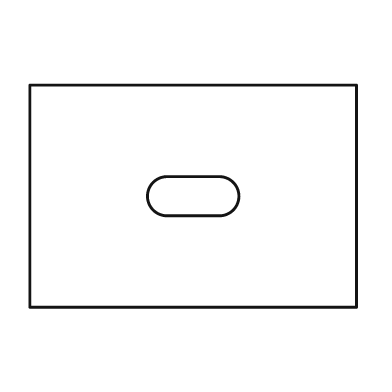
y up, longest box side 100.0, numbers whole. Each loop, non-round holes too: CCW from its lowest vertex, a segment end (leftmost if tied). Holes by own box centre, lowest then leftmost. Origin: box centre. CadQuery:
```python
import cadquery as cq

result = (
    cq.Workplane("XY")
    .moveTo(-50.0, -34.0)
    .lineTo(50.0, -34.0)
    .lineTo(50.0, 34.0)
    .lineTo(-50.0, 34.0)
    .close()
    .moveTo(-8.0, -6.0)
    .lineTo(8.0, -6.0)
    .threePointArc((14.0, 0.0), (8.0, 6.0))
    .lineTo(-8.0, 6.0)
    .threePointArc((-14.0, 0.0), (-8.0, -6.0))
    .close()
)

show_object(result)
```